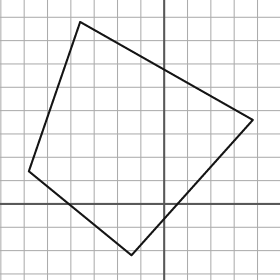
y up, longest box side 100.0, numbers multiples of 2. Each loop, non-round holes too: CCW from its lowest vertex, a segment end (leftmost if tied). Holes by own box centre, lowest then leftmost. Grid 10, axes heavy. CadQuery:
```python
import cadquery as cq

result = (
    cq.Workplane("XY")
    .moveTo(-14.0, -22.0)
    .lineTo(38.0, 36.0)
    .lineTo(-36.0, 78.0)
    .lineTo(-58.0, 14.0)
    .close()
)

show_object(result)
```